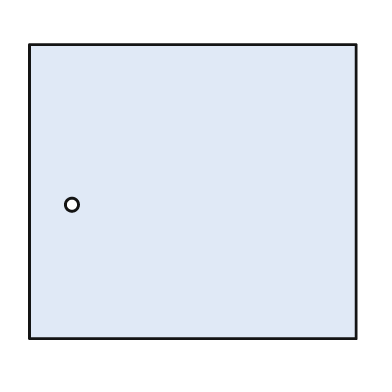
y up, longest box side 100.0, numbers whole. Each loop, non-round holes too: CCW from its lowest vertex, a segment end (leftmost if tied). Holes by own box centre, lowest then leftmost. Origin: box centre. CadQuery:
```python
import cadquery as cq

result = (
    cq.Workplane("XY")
    .moveTo(-50.0, -45.0)
    .lineTo(50.0, -45.0)
    .lineTo(50.0, 45.0)
    .lineTo(-50.0, 45.0)
    .close()
    .moveTo(-37.0, -4.0)
    .circle(2.0)
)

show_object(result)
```